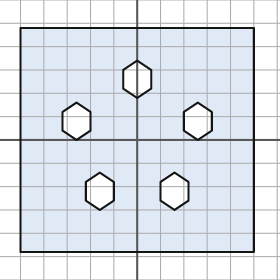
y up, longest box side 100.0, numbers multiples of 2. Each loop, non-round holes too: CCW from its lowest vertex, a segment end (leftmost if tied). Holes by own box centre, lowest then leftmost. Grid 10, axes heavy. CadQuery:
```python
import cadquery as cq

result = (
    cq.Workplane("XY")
    .moveTo(-50.0, -48.0)
    .lineTo(50.0, -48.0)
    .lineTo(50.0, 48.0)
    .lineTo(-50.0, 48.0)
    .close()
    .moveTo(-16.0, -30.0)
    .lineTo(-10.0, -26.0)
    .lineTo(-10.0, -18.0)
    .lineTo(-16.0, -14.0)
    .lineTo(-22.0, -18.0)
    .lineTo(-22.0, -26.0)
    .close()
    .moveTo(16.0, -30.0)
    .lineTo(22.0, -26.0)
    .lineTo(22.0, -18.0)
    .lineTo(16.0, -14.0)
    .lineTo(10.0, -18.0)
    .lineTo(10.0, -26.0)
    .close()
    .moveTo(-26.0, 0.0)
    .lineTo(-20.0, 4.0)
    .lineTo(-20.0, 12.0)
    .lineTo(-26.0, 16.0)
    .lineTo(-32.0, 12.0)
    .lineTo(-32.0, 4.0)
    .close()
    .moveTo(26.0, 0.0)
    .lineTo(32.0, 4.0)
    .lineTo(32.0, 12.0)
    .lineTo(26.0, 16.0)
    .lineTo(20.0, 12.0)
    .lineTo(20.0, 4.0)
    .close()
    .moveTo(0.0, 18.0)
    .lineTo(6.0, 22.0)
    .lineTo(6.0, 30.0)
    .lineTo(0.0, 34.0)
    .lineTo(-6.0, 30.0)
    .lineTo(-6.0, 22.0)
    .close()
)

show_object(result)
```